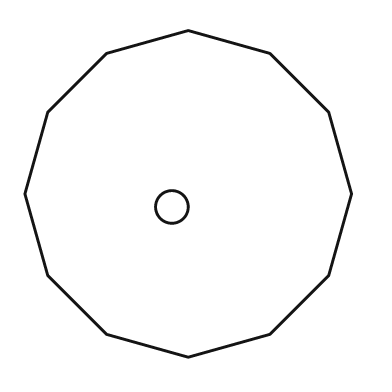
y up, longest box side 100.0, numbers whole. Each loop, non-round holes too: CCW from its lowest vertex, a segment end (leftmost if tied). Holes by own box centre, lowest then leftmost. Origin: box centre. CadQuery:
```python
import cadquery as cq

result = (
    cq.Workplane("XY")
    .moveTo(0.0, -50.0)
    .lineTo(25.0, -43.0)
    .lineTo(43.0, -25.0)
    .lineTo(50.0, 0.0)
    .lineTo(43.0, 25.0)
    .lineTo(25.0, 43.0)
    .lineTo(0.0, 50.0)
    .lineTo(-25.0, 43.0)
    .lineTo(-43.0, 25.0)
    .lineTo(-50.0, 0.0)
    .lineTo(-43.0, -25.0)
    .lineTo(-25.0, -43.0)
    .close()
    .moveTo(-5.0, -4.0)
    .circle(5.0)
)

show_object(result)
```